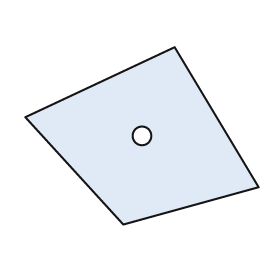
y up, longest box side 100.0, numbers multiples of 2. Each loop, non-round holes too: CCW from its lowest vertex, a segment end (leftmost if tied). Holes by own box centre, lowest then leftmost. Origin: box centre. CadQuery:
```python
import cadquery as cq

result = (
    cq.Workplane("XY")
    .moveTo(-8.0, -38.0)
    .lineTo(50.0, -22.0)
    .lineTo(14.0, 38.0)
    .lineTo(-50.0, 8.0)
    .close()
    .moveTo(0.0, 0.0)
    .circle(4.0)
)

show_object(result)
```